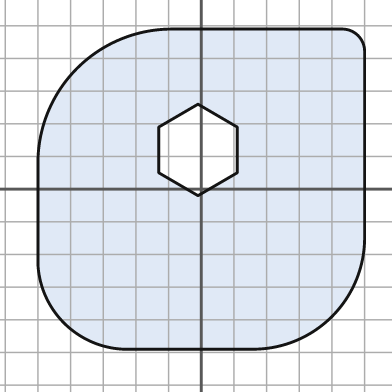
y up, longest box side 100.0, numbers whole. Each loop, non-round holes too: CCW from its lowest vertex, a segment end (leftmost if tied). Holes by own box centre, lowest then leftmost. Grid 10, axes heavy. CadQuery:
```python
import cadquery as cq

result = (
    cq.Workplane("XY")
    .moveTo(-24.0, -49.0)
    .lineTo(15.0, -49.0)
    .threePointArc((40.0, -39.0), (50.0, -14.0))
    .lineTo(50.0, 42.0)
    .threePointArc((48.0, 47.0), (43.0, 49.0))
    .lineTo(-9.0, 49.0)
    .threePointArc((-38.0, 37.0), (-50.0, 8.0))
    .lineTo(-50.0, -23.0)
    .threePointArc((-42.0, -41.0), (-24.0, -49.0))
    .close()
    .moveTo(-1.0, -2.0)
    .lineTo(11.0, 5.0)
    .lineTo(11.0, 19.0)
    .lineTo(-1.0, 26.0)
    .lineTo(-13.0, 19.0)
    .lineTo(-13.0, 5.0)
    .close()
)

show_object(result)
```